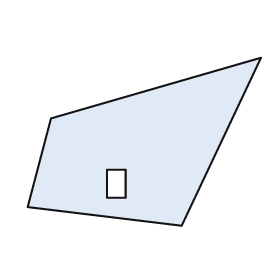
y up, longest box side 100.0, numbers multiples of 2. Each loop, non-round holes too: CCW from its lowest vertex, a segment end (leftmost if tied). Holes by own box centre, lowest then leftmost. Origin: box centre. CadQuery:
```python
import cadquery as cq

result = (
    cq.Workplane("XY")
    .moveTo(16.0, -36.0)
    .lineTo(50.0, 36.0)
    .lineTo(-40.0, 10.0)
    .lineTo(-50.0, -28.0)
    .close()
    .moveTo(-16.0, -24.0)
    .lineTo(-8.0, -24.0)
    .lineTo(-8.0, -12.0)
    .lineTo(-16.0, -12.0)
    .close()
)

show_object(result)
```